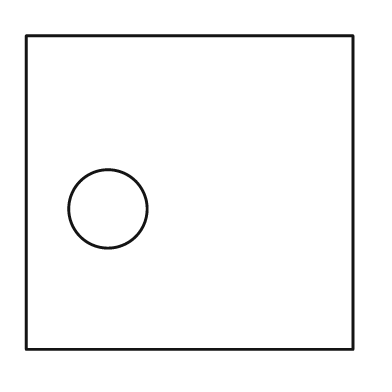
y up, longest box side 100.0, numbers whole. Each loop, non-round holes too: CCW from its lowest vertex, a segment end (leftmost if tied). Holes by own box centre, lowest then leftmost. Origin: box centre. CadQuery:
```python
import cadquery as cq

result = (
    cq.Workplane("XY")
    .moveTo(-50.0, -48.0)
    .lineTo(50.0, -48.0)
    .lineTo(50.0, 48.0)
    .lineTo(-50.0, 48.0)
    .close()
    .moveTo(-25.0, -5.0)
    .circle(12.0)
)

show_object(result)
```